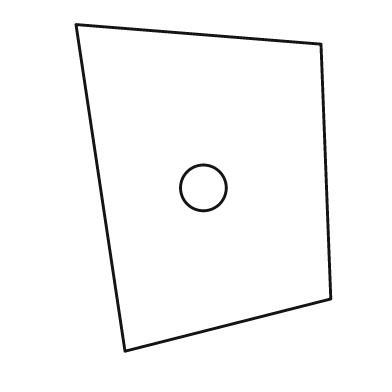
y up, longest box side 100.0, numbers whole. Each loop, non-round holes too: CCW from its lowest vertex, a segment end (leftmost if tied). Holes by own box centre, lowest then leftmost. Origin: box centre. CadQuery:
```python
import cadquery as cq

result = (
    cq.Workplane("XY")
    .moveTo(-24.0, -50.0)
    .lineTo(39.0, -34.0)
    .lineTo(36.0, 44.0)
    .lineTo(-39.0, 50.0)
    .close()
    .moveTo(0.0, 0.0)
    .circle(7.0)
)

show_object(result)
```